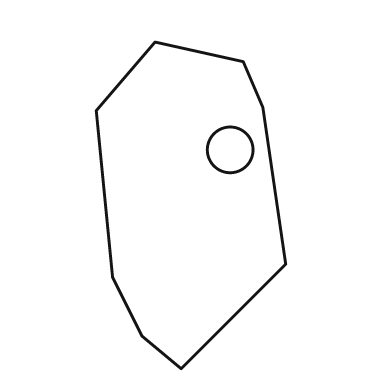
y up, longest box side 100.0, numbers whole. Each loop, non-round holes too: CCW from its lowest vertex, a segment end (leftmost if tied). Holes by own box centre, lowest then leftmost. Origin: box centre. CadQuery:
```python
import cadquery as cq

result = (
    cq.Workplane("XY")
    .moveTo(-3.0, -50.0)
    .lineTo(29.0, -18.0)
    .lineTo(22.0, 30.0)
    .lineTo(16.0, 44.0)
    .lineTo(-11.0, 50.0)
    .lineTo(-29.0, 29.0)
    .lineTo(-24.0, -22.0)
    .lineTo(-15.0, -40.0)
    .close()
    .moveTo(12.0, 17.0)
    .circle(7.0)
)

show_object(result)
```